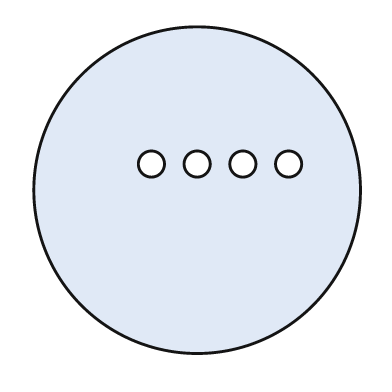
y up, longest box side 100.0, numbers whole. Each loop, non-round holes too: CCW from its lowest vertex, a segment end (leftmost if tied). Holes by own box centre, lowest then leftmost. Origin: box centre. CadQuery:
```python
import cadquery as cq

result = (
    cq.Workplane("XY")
    .moveTo(0.0, 0.0)
    .circle(50.0)
    .moveTo(-14.0, 8.0)
    .circle(4.0)
    .moveTo(0.0, 8.0)
    .circle(4.0)
    .moveTo(14.0, 8.0)
    .circle(4.0)
    .moveTo(28.0, 8.0)
    .circle(4.0)
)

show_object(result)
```